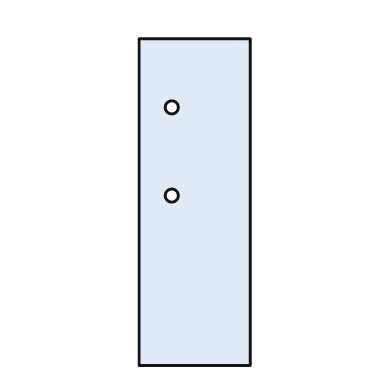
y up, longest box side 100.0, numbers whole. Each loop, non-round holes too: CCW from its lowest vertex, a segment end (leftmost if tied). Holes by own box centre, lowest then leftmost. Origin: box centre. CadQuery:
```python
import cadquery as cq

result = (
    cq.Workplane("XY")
    .moveTo(-17.0, -50.0)
    .lineTo(17.0, -50.0)
    .lineTo(17.0, 50.0)
    .lineTo(-17.0, 50.0)
    .close()
    .moveTo(-7.0, 2.0)
    .circle(2.0)
    .moveTo(-7.0, 29.0)
    .circle(2.0)
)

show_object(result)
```